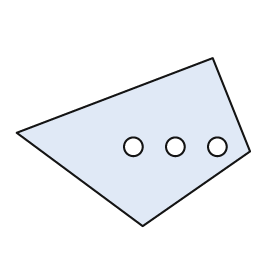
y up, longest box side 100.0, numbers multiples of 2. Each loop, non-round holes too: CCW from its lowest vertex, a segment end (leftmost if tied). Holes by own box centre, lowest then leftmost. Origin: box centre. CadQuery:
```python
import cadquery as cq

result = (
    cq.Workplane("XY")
    .moveTo(4.0, -36.0)
    .lineTo(50.0, -4.0)
    .lineTo(34.0, 36.0)
    .lineTo(-50.0, 4.0)
    .close()
    .moveTo(0.0, -2.0)
    .circle(4.0)
    .moveTo(18.0, -2.0)
    .circle(4.0)
    .moveTo(36.0, -2.0)
    .circle(4.0)
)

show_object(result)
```